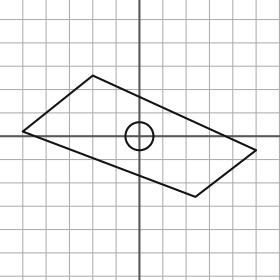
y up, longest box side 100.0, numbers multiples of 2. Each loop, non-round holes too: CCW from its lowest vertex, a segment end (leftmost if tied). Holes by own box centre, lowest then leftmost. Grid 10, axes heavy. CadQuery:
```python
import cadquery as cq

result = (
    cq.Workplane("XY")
    .moveTo(24.0, -26.0)
    .lineTo(50.0, -6.0)
    .lineTo(-20.0, 26.0)
    .lineTo(-50.0, 2.0)
    .close()
    .moveTo(0.0, 0.0)
    .circle(6.0)
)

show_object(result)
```